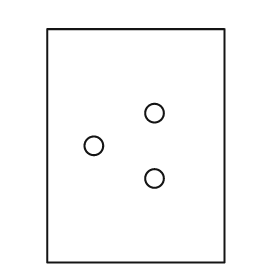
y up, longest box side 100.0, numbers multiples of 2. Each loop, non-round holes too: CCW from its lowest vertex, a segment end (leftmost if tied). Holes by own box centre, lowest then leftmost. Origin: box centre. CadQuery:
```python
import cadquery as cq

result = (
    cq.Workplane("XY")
    .moveTo(-38.0, -50.0)
    .lineTo(38.0, -50.0)
    .lineTo(38.0, 50.0)
    .lineTo(-38.0, 50.0)
    .close()
    .moveTo(8.0, -14.0)
    .circle(4.0)
    .moveTo(-18.0, 0.0)
    .circle(4.0)
    .moveTo(8.0, 14.0)
    .circle(4.0)
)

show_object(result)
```